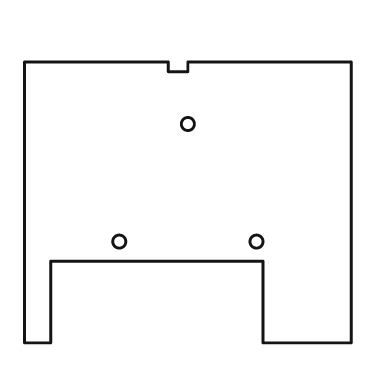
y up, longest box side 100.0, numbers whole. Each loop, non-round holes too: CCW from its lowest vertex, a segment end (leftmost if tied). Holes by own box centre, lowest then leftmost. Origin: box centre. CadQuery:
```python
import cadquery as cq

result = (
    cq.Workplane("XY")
    .moveTo(-50.0, -43.0)
    .lineTo(-42.0, -43.0)
    .lineTo(-42.0, -18.0)
    .lineTo(23.0, -18.0)
    .lineTo(23.0, -43.0)
    .lineTo(50.0, -43.0)
    .lineTo(50.0, 43.0)
    .lineTo(0.0, 43.0)
    .lineTo(0.0, 40.0)
    .lineTo(-6.0, 40.0)
    .lineTo(-6.0, 43.0)
    .lineTo(-50.0, 43.0)
    .close()
    .moveTo(-21.0, -12.0)
    .circle(2.0)
    .moveTo(21.0, -12.0)
    .circle(2.0)
    .moveTo(0.0, 24.0)
    .circle(2.0)
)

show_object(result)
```